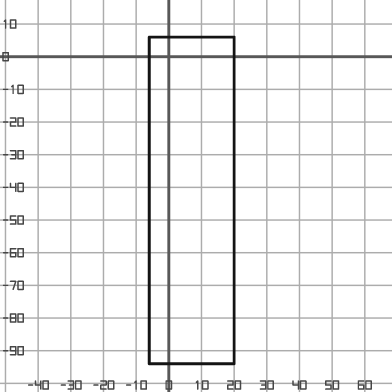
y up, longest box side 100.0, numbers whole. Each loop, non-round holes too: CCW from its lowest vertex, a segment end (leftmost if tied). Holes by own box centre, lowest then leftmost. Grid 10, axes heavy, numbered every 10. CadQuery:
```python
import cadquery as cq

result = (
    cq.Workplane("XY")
    .moveTo(-6.0, -94.0)
    .lineTo(20.0, -94.0)
    .lineTo(20.0, 6.0)
    .lineTo(-6.0, 6.0)
    .close()
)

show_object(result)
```